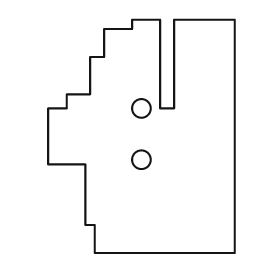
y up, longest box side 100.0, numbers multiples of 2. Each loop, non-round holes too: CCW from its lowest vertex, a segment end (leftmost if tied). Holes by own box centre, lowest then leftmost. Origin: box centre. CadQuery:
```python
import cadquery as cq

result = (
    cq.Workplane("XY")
    .moveTo(-20.0, -50.0)
    .lineTo(40.0, -50.0)
    .lineTo(40.0, 50.0)
    .lineTo(14.0, 50.0)
    .lineTo(14.0, 12.0)
    .lineTo(8.0, 12.0)
    .lineTo(8.0, 50.0)
    .lineTo(-4.0, 50.0)
    .lineTo(-4.0, 46.0)
    .lineTo(-16.0, 46.0)
    .lineTo(-16.0, 34.0)
    .lineTo(-22.0, 34.0)
    .lineTo(-22.0, 18.0)
    .lineTo(-32.0, 18.0)
    .lineTo(-32.0, 12.0)
    .lineTo(-40.0, 12.0)
    .lineTo(-40.0, -12.0)
    .lineTo(-24.0, -12.0)
    .lineTo(-24.0, -38.0)
    .lineTo(-20.0, -38.0)
    .close()
    .moveTo(0.0, -10.0)
    .circle(4.0)
    .moveTo(0.0, 12.0)
    .circle(4.0)
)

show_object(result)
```